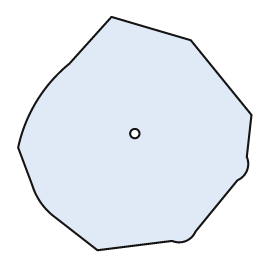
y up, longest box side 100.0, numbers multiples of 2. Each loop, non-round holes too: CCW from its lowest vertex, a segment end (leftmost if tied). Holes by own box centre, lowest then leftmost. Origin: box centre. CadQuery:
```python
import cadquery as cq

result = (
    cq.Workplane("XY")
    .moveTo(-16.0, -50.0)
    .lineTo(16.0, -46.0)
    .threePointArc((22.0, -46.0), (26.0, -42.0))
    .lineTo(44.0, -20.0)
    .threePointArc((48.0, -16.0), (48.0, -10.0))
    .lineTo(50.0, 8.0)
    .lineTo(24.0, 40.0)
    .lineTo(-10.0, 50.0)
    .lineTo(-28.0, 30.0)
    .threePointArc((-42.0, 14.0), (-50.0, -6.0))
    .lineTo(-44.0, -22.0)
    .threePointArc((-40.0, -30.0), (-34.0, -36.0))
    .close()
    .moveTo(0.0, 0.0)
    .circle(2.0)
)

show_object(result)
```